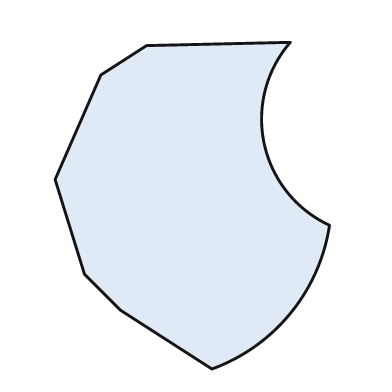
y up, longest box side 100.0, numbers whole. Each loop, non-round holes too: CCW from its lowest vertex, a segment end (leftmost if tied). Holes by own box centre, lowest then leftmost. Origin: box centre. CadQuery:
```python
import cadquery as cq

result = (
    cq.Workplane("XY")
    .moveTo(6.0, -50.0)
    .threePointArc((30.0, -33.0), (42.0, -6.0))
    .threePointArc((22.0, 19.0), (30.0, 50.0))
    .lineTo(-14.0, 49.0)
    .lineTo(-28.0, 40.0)
    .lineTo(-42.0, 8.0)
    .lineTo(-33.0, -21.0)
    .lineTo(-22.0, -32.0)
    .close()
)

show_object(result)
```